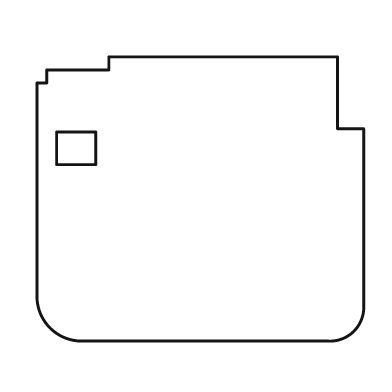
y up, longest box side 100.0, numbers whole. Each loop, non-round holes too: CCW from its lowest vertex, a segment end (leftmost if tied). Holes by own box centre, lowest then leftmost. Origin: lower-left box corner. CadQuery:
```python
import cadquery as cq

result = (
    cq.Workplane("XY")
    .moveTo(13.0, 0.0)
    .lineTo(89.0, 0.0)
    .threePointArc((97.0, 3.0), (100.0, 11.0))
    .lineTo(100.0, 65.0)
    .lineTo(92.0, 65.0)
    .lineTo(92.0, 87.0)
    .lineTo(22.0, 87.0)
    .lineTo(22.0, 83.0)
    .lineTo(3.0, 83.0)
    .lineTo(3.0, 79.0)
    .lineTo(0.0, 79.0)
    .lineTo(0.0, 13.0)
    .threePointArc((4.0, 4.0), (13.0, 0.0))
    .close()
    .moveTo(6.0, 54.0)
    .lineTo(18.0, 54.0)
    .lineTo(18.0, 64.0)
    .lineTo(6.0, 64.0)
    .close()
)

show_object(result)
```